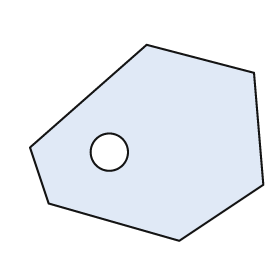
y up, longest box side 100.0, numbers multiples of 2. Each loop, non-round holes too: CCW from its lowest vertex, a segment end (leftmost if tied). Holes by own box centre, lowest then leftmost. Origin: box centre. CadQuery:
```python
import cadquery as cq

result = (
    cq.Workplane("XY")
    .moveTo(14.0, -42.0)
    .lineTo(50.0, -18.0)
    .lineTo(46.0, 30.0)
    .lineTo(0.0, 42.0)
    .lineTo(-50.0, -2.0)
    .lineTo(-42.0, -26.0)
    .close()
    .moveTo(-16.0, -4.0)
    .circle(8.0)
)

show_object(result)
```